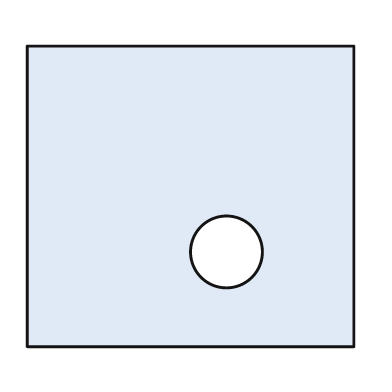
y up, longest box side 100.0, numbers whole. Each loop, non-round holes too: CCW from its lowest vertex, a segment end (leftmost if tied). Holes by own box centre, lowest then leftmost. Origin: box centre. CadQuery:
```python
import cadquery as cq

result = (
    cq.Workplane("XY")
    .moveTo(-50.0, -46.0)
    .lineTo(50.0, -46.0)
    .lineTo(50.0, 46.0)
    .lineTo(-50.0, 46.0)
    .close()
    .moveTo(11.0, -17.0)
    .circle(11.0)
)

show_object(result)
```